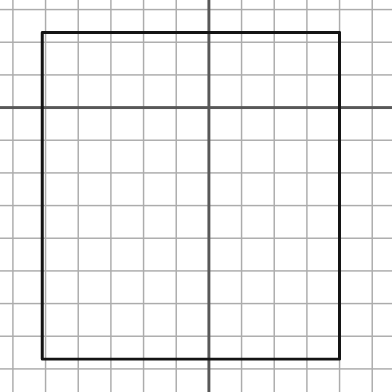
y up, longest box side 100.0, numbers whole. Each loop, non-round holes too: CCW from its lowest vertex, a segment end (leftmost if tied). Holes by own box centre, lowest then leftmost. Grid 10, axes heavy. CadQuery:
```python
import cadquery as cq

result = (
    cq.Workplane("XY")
    .moveTo(-51.0, -77.0)
    .lineTo(40.0, -77.0)
    .lineTo(40.0, 23.0)
    .lineTo(-51.0, 23.0)
    .close()
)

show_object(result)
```